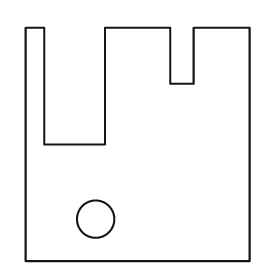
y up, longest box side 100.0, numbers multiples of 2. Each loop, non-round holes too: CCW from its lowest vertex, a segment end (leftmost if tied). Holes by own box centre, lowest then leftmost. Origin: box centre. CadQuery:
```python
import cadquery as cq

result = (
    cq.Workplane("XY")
    .moveTo(-48.0, -50.0)
    .lineTo(48.0, -50.0)
    .lineTo(48.0, 50.0)
    .lineTo(24.0, 50.0)
    .lineTo(24.0, 26.0)
    .lineTo(14.0, 26.0)
    .lineTo(14.0, 50.0)
    .lineTo(-14.0, 50.0)
    .lineTo(-14.0, 0.0)
    .lineTo(-40.0, 0.0)
    .lineTo(-40.0, 50.0)
    .lineTo(-48.0, 50.0)
    .close()
    .moveTo(-18.0, -32.0)
    .circle(8.0)
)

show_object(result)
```